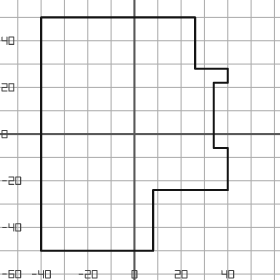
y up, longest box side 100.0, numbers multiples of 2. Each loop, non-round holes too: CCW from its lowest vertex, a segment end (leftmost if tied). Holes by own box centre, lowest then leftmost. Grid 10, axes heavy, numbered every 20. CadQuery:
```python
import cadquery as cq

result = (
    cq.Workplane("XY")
    .moveTo(-40.0, -50.0)
    .lineTo(8.0, -50.0)
    .lineTo(8.0, -24.0)
    .lineTo(40.0, -24.0)
    .lineTo(40.0, -6.0)
    .lineTo(34.0, -6.0)
    .lineTo(34.0, 22.0)
    .lineTo(40.0, 22.0)
    .lineTo(40.0, 28.0)
    .lineTo(26.0, 28.0)
    .lineTo(26.0, 50.0)
    .lineTo(-40.0, 50.0)
    .close()
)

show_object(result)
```